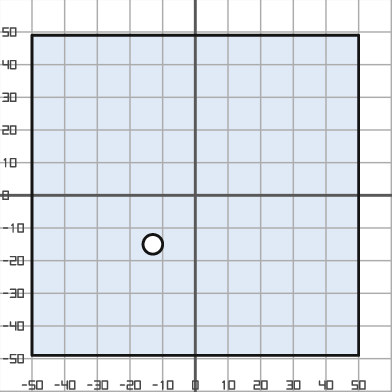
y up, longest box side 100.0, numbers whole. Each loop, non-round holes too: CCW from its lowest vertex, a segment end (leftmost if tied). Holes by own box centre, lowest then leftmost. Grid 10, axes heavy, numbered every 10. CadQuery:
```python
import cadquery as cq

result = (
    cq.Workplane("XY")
    .moveTo(-50.0, -49.0)
    .lineTo(50.0, -49.0)
    .lineTo(50.0, 49.0)
    .lineTo(-50.0, 49.0)
    .close()
    .moveTo(-13.0, -15.0)
    .circle(3.0)
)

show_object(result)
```